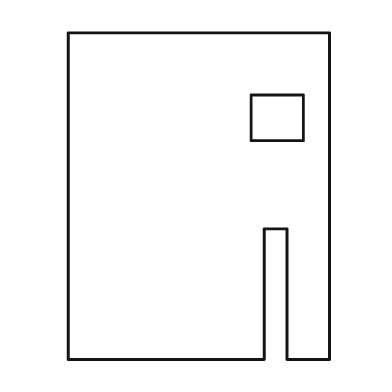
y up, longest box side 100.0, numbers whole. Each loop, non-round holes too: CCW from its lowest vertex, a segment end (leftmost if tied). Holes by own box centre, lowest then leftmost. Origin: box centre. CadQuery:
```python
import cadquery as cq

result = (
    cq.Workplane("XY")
    .moveTo(-40.0, -50.0)
    .lineTo(20.0, -50.0)
    .lineTo(20.0, -10.0)
    .lineTo(27.0, -10.0)
    .lineTo(27.0, -50.0)
    .lineTo(40.0, -50.0)
    .lineTo(40.0, 50.0)
    .lineTo(-40.0, 50.0)
    .close()
    .moveTo(16.0, 17.0)
    .lineTo(32.0, 17.0)
    .lineTo(32.0, 31.0)
    .lineTo(16.0, 31.0)
    .close()
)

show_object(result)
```